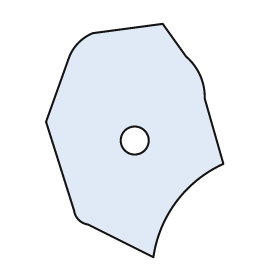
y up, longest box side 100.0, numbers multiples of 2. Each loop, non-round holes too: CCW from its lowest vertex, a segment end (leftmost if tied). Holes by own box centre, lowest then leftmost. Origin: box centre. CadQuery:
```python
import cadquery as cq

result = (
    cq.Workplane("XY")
    .moveTo(8.0, -50.0)
    .threePointArc((18.0, -26.0), (38.0, -10.0))
    .lineTo(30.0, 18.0)
    .threePointArc((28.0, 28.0), (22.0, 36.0))
    .lineTo(12.0, 50.0)
    .lineTo(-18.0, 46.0)
    .threePointArc((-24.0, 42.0), (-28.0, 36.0))
    .lineTo(-38.0, 8.0)
    .lineTo(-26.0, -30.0)
    .threePointArc((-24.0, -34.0), (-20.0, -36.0))
    .close()
    .moveTo(0.0, 0.0)
    .circle(6.0)
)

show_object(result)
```